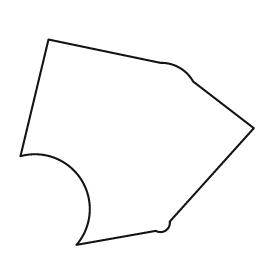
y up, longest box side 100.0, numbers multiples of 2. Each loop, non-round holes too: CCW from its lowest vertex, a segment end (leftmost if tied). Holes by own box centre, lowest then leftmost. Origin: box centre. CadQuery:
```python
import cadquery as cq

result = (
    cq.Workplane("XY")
    .moveTo(-26.0, -44.0)
    .lineTo(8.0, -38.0)
    .threePointArc((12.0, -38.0), (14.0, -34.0))
    .lineTo(50.0, 6.0)
    .lineTo(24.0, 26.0)
    .threePointArc((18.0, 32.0), (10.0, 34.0))
    .lineTo(-38.0, 44.0)
    .lineTo(-50.0, -6.0)
    .threePointArc((-24.0, -16.0), (-26.0, -44.0))
    .close()
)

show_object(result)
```